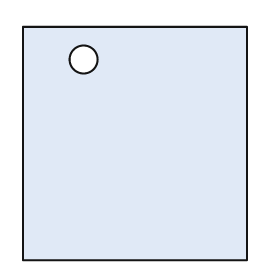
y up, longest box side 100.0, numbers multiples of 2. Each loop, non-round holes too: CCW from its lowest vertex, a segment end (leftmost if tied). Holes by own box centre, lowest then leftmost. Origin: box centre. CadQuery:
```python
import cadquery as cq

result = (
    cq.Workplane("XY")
    .moveTo(-48.0, -50.0)
    .lineTo(48.0, -50.0)
    .lineTo(48.0, 50.0)
    .lineTo(-48.0, 50.0)
    .close()
    .moveTo(-22.0, 36.0)
    .circle(6.0)
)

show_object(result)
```